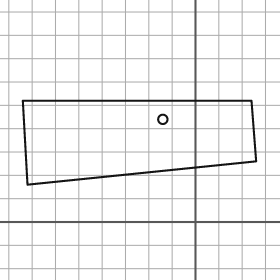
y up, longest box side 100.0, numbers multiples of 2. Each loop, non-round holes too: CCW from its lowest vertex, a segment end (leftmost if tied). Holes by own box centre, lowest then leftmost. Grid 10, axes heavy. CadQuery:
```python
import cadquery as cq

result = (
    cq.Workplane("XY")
    .moveTo(-72.0, 16.0)
    .lineTo(26.0, 26.0)
    .lineTo(24.0, 52.0)
    .lineTo(-74.0, 52.0)
    .close()
    .moveTo(-14.0, 44.0)
    .circle(2.0)
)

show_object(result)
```